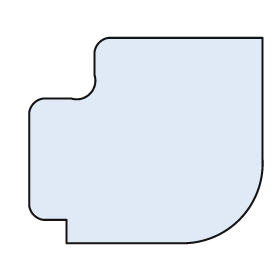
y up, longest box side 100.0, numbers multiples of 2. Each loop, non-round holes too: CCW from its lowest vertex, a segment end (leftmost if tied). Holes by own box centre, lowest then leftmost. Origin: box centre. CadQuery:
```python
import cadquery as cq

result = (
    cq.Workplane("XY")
    .moveTo(-34.0, -44.0)
    .lineTo(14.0, -44.0)
    .threePointArc((40.0, -34.0), (50.0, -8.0))
    .lineTo(50.0, 44.0)
    .lineTo(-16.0, 44.0)
    .threePointArc((-20.0, 42.0), (-22.0, 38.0))
    .lineTo(-22.0, 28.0)
    .threePointArc((-24.0, 20.0), (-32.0, 18.0))
    .lineTo(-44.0, 18.0)
    .threePointArc((-48.0, 16.0), (-50.0, 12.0))
    .lineTo(-50.0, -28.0)
    .threePointArc((-48.0, -32.0), (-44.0, -34.0))
    .lineTo(-34.0, -34.0)
    .close()
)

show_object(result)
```